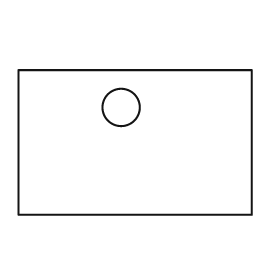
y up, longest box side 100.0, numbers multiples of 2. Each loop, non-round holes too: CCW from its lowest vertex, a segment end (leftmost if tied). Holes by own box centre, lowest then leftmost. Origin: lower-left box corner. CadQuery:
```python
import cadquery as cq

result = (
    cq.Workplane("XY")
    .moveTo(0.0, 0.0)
    .lineTo(100.0, 0.0)
    .lineTo(100.0, 62.0)
    .lineTo(0.0, 62.0)
    .close()
    .moveTo(44.0, 46.0)
    .circle(8.0)
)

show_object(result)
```